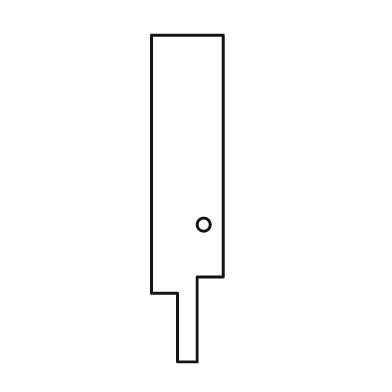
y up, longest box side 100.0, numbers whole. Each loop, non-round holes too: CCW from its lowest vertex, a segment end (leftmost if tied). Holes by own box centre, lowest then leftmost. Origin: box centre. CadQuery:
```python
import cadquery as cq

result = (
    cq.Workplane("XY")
    .moveTo(-3.0, -50.0)
    .lineTo(3.0, -50.0)
    .lineTo(3.0, -24.0)
    .lineTo(11.0, -24.0)
    .lineTo(11.0, 50.0)
    .lineTo(-11.0, 50.0)
    .lineTo(-11.0, -29.0)
    .lineTo(-3.0, -29.0)
    .close()
    .moveTo(5.0, -8.0)
    .circle(2.0)
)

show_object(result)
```